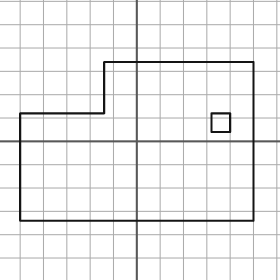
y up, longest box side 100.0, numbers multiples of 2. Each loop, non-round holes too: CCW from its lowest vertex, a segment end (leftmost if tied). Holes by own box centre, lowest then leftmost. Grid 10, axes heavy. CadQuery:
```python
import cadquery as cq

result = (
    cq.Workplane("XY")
    .moveTo(-50.0, -34.0)
    .lineTo(50.0, -34.0)
    .lineTo(50.0, 34.0)
    .lineTo(-14.0, 34.0)
    .lineTo(-14.0, 12.0)
    .lineTo(-50.0, 12.0)
    .close()
    .moveTo(32.0, 4.0)
    .lineTo(40.0, 4.0)
    .lineTo(40.0, 12.0)
    .lineTo(32.0, 12.0)
    .close()
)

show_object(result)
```